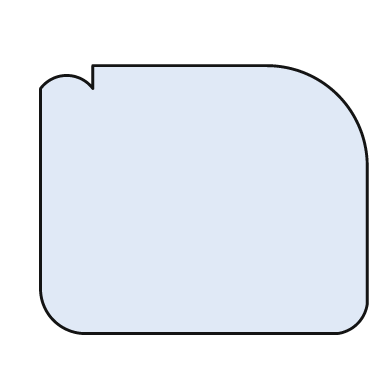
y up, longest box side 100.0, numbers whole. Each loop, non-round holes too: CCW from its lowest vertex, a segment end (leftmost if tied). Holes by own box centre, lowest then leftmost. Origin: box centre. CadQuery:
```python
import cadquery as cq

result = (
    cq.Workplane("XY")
    .moveTo(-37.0, -41.0)
    .lineTo(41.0, -41.0)
    .threePointArc((47.0, -38.0), (50.0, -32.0))
    .lineTo(50.0, 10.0)
    .threePointArc((41.0, 32.0), (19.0, 41.0))
    .lineTo(-34.0, 41.0)
    .lineTo(-34.0, 34.0)
    .threePointArc((-42.0, 38.0), (-50.0, 34.0))
    .lineTo(-50.0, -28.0)
    .threePointArc((-46.0, -37.0), (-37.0, -41.0))
    .close()
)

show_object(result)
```